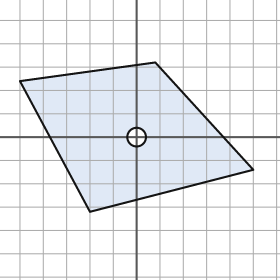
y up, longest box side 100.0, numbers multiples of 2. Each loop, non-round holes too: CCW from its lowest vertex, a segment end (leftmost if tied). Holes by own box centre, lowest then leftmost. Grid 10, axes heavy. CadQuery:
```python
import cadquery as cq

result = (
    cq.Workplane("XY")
    .moveTo(-20.0, -32.0)
    .lineTo(50.0, -14.0)
    .lineTo(8.0, 32.0)
    .lineTo(-50.0, 24.0)
    .close()
    .moveTo(0.0, 0.0)
    .circle(4.0)
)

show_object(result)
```